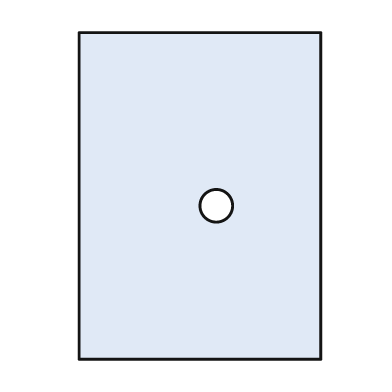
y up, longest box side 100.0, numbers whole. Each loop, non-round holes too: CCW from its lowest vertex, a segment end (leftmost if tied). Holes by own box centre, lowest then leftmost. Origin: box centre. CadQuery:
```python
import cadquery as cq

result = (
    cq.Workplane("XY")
    .moveTo(-37.0, -50.0)
    .lineTo(37.0, -50.0)
    .lineTo(37.0, 50.0)
    .lineTo(-37.0, 50.0)
    .close()
    .moveTo(5.0, -3.0)
    .circle(5.0)
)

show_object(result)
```